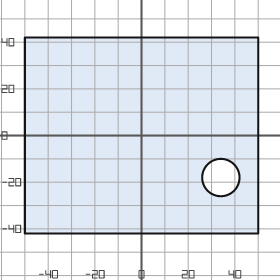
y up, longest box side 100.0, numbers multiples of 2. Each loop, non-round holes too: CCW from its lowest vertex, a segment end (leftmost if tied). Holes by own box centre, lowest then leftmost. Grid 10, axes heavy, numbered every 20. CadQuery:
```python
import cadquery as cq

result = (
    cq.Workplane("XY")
    .moveTo(-50.0, -42.0)
    .lineTo(50.0, -42.0)
    .lineTo(50.0, 42.0)
    .lineTo(-50.0, 42.0)
    .close()
    .moveTo(34.0, -18.0)
    .circle(8.0)
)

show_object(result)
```